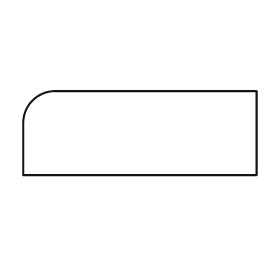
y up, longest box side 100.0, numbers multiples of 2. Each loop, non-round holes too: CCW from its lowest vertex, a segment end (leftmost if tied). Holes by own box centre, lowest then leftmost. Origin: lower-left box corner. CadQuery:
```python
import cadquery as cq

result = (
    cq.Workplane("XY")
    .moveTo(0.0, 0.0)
    .lineTo(100.0, 0.0)
    .lineTo(100.0, 36.0)
    .lineTo(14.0, 36.0)
    .threePointArc((4.0, 32.0), (0.0, 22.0))
    .close()
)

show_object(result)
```